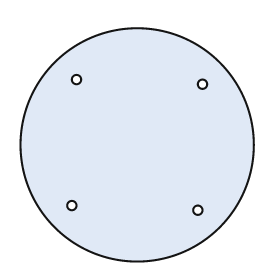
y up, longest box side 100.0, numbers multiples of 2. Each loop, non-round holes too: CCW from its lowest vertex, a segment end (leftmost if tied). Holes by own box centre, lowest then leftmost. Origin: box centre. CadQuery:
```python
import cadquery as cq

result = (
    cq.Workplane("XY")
    .moveTo(0.0, 0.0)
    .circle(50.0)
    .moveTo(26.0, -28.0)
    .circle(2.0)
    .moveTo(-28.0, -26.0)
    .circle(2.0)
    .moveTo(28.0, 26.0)
    .circle(2.0)
    .moveTo(-26.0, 28.0)
    .circle(2.0)
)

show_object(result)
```